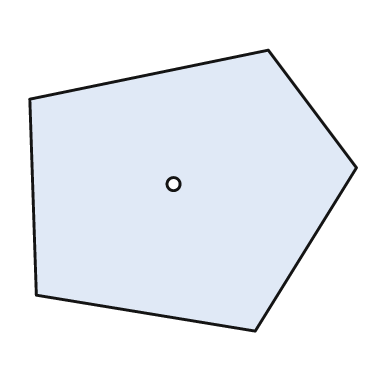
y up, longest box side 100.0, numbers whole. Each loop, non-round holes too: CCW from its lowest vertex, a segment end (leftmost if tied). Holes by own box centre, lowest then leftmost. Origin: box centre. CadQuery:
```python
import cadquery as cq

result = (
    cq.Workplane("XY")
    .moveTo(19.0, -43.0)
    .lineTo(50.0, 7.0)
    .lineTo(23.0, 43.0)
    .lineTo(-50.0, 28.0)
    .lineTo(-48.0, -32.0)
    .close()
    .moveTo(-6.0, 2.0)
    .circle(2.0)
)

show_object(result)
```